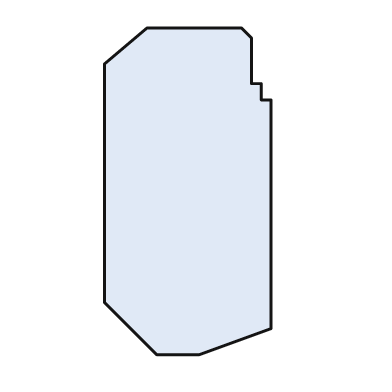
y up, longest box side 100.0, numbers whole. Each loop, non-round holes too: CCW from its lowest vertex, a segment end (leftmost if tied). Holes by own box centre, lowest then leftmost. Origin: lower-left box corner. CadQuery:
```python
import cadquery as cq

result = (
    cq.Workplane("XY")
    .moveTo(16.0, 0.0)
    .lineTo(29.0, 0.0)
    .lineTo(51.0, 8.0)
    .lineTo(51.0, 78.0)
    .lineTo(48.0, 78.0)
    .lineTo(48.0, 83.0)
    .lineTo(45.0, 83.0)
    .lineTo(45.0, 97.0)
    .lineTo(42.0, 100.0)
    .lineTo(13.0, 100.0)
    .lineTo(0.0, 89.0)
    .lineTo(0.0, 16.0)
    .close()
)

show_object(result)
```